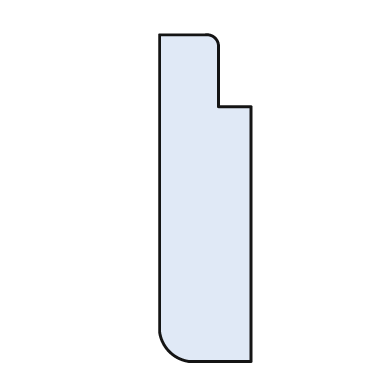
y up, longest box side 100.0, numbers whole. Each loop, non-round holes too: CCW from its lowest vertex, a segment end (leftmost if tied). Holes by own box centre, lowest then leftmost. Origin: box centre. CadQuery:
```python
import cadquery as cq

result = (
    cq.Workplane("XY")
    .moveTo(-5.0, -50.0)
    .lineTo(14.0, -50.0)
    .lineTo(14.0, 28.0)
    .lineTo(4.0, 28.0)
    .lineTo(4.0, 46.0)
    .threePointArc((3.0, 49.0), (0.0, 50.0))
    .lineTo(-14.0, 50.0)
    .lineTo(-14.0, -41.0)
    .threePointArc((-11.0, -47.0), (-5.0, -50.0))
    .close()
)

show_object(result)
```